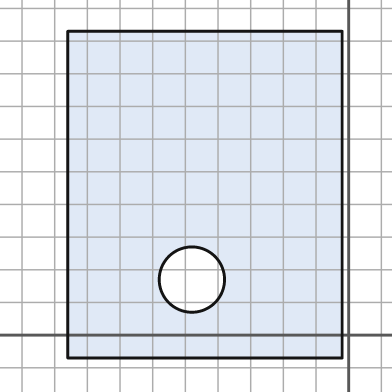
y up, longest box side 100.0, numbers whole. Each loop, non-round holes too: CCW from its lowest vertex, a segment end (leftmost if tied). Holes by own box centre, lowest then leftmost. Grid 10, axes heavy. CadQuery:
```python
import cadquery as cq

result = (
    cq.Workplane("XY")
    .moveTo(-86.0, -7.0)
    .lineTo(-2.0, -7.0)
    .lineTo(-2.0, 93.0)
    .lineTo(-86.0, 93.0)
    .close()
    .moveTo(-48.0, 17.0)
    .circle(10.0)
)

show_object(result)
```